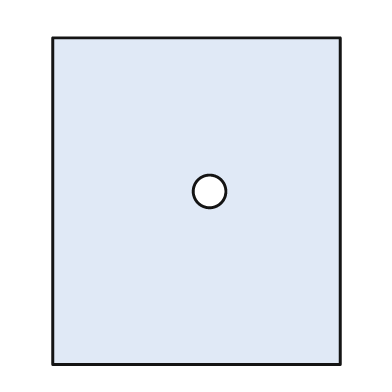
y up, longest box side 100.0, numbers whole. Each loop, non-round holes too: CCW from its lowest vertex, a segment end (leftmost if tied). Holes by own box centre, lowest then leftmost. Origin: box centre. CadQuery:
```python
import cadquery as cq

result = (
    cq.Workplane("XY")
    .moveTo(-44.0, -50.0)
    .lineTo(44.0, -50.0)
    .lineTo(44.0, 50.0)
    .lineTo(-44.0, 50.0)
    .close()
    .moveTo(4.0, 3.0)
    .circle(5.0)
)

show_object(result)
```